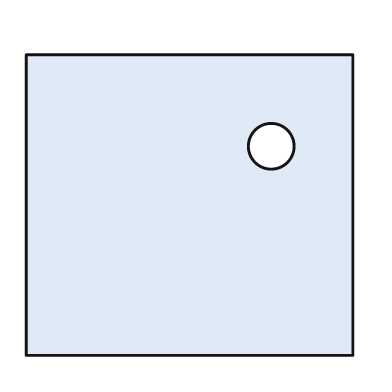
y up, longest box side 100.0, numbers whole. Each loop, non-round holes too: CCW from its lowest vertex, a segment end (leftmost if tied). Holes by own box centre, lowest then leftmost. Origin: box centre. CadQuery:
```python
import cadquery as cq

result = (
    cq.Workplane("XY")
    .moveTo(-50.0, -46.0)
    .lineTo(50.0, -46.0)
    .lineTo(50.0, 46.0)
    .lineTo(-50.0, 46.0)
    .close()
    .moveTo(25.0, 18.0)
    .circle(7.0)
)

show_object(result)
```